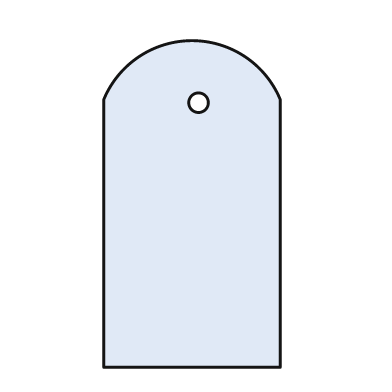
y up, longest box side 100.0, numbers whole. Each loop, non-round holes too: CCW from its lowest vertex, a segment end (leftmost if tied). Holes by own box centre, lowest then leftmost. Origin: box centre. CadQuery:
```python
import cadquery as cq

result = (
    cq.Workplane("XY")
    .moveTo(-27.0, -50.0)
    .lineTo(27.0, -50.0)
    .lineTo(27.0, 32.0)
    .threePointArc((0.0, 50.0), (-27.0, 32.0))
    .close()
    .moveTo(2.0, 31.0)
    .circle(3.0)
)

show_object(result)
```